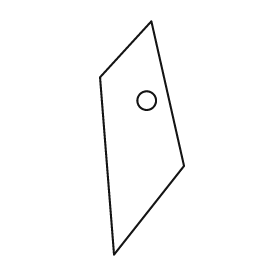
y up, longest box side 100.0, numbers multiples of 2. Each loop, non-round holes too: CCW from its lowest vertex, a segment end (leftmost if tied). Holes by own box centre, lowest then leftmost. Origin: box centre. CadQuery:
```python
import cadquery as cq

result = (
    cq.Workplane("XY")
    .moveTo(-12.0, -50.0)
    .lineTo(18.0, -12.0)
    .lineTo(4.0, 50.0)
    .lineTo(-18.0, 26.0)
    .close()
    .moveTo(2.0, 16.0)
    .circle(4.0)
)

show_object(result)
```